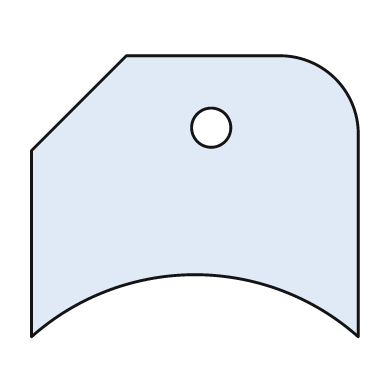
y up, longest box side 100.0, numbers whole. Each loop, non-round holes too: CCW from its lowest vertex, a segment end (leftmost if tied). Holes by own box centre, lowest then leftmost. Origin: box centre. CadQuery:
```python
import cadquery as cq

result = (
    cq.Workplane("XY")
    .moveTo(-50.0, -43.0)
    .threePointArc((0.0, -24.0), (50.0, -43.0))
    .lineTo(50.0, 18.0)
    .threePointArc((43.0, 36.0), (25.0, 43.0))
    .lineTo(-21.0, 43.0)
    .lineTo(-50.0, 14.0)
    .close()
    .moveTo(5.0, 21.0)
    .circle(6.0)
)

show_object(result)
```